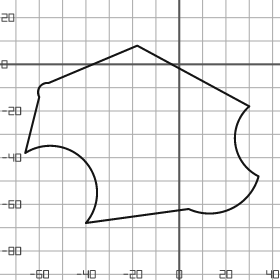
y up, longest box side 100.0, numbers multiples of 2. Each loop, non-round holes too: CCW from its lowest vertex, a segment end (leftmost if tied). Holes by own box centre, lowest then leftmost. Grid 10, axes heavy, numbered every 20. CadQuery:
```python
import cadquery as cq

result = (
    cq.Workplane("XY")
    .moveTo(-40.0, -68.0)
    .lineTo(4.0, -62.0)
    .threePointArc((22.0, -62.0), (34.0, -48.0))
    .threePointArc((24.0, -34.0), (30.0, -18.0))
    .lineTo(-18.0, 8.0)
    .lineTo(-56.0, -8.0)
    .threePointArc((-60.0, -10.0), (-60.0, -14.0))
    .lineTo(-66.0, -38.0)
    .threePointArc((-40.0, -42.0), (-40.0, -68.0))
    .close()
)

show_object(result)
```